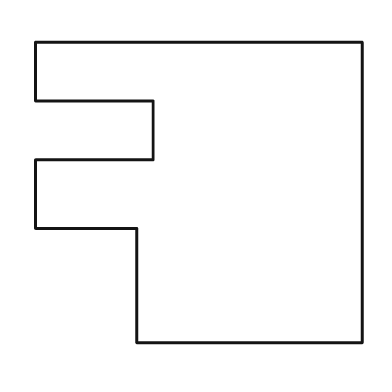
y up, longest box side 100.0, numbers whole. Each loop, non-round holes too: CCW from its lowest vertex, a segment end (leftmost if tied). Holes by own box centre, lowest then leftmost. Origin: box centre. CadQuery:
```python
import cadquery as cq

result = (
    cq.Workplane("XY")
    .moveTo(-19.0, -46.0)
    .lineTo(50.0, -46.0)
    .lineTo(50.0, 46.0)
    .lineTo(-50.0, 46.0)
    .lineTo(-50.0, 28.0)
    .lineTo(-14.0, 28.0)
    .lineTo(-14.0, 10.0)
    .lineTo(-50.0, 10.0)
    .lineTo(-50.0, -11.0)
    .lineTo(-19.0, -11.0)
    .close()
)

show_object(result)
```